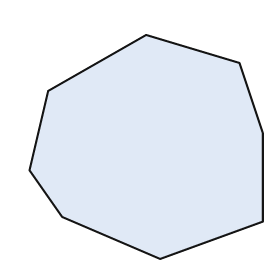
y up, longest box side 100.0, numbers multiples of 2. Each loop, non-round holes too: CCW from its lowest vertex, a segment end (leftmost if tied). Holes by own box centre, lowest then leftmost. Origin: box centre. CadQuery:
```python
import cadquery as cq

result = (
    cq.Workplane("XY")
    .moveTo(6.0, -48.0)
    .lineTo(50.0, -32.0)
    .lineTo(50.0, 6.0)
    .lineTo(40.0, 36.0)
    .lineTo(0.0, 48.0)
    .lineTo(-42.0, 24.0)
    .lineTo(-50.0, -10.0)
    .lineTo(-36.0, -30.0)
    .close()
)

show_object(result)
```